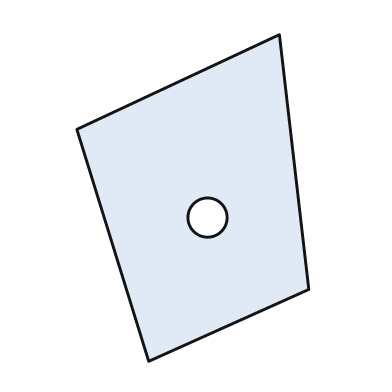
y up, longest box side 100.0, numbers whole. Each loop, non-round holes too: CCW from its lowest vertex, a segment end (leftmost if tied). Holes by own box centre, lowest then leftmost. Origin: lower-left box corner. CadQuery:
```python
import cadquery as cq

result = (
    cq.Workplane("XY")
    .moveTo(22.0, 0.0)
    .lineTo(71.0, 22.0)
    .lineTo(62.0, 100.0)
    .lineTo(0.0, 71.0)
    .close()
    .moveTo(40.0, 44.0)
    .circle(6.0)
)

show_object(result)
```